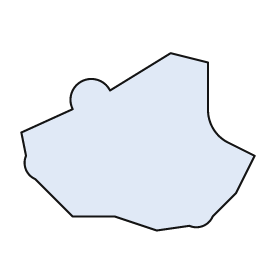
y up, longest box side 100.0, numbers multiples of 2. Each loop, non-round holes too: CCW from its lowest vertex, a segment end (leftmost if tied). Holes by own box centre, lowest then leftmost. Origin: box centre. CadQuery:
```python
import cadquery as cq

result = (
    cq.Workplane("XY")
    .moveTo(8.0, -38.0)
    .lineTo(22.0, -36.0)
    .threePointArc((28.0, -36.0), (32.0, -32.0))
    .lineTo(42.0, -22.0)
    .lineTo(50.0, -6.0)
    .lineTo(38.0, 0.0)
    .threePointArc((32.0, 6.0), (30.0, 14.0))
    .lineTo(30.0, 34.0)
    .lineTo(14.0, 38.0)
    .lineTo(-12.0, 22.0)
    .threePointArc((-24.0, 26.0), (-28.0, 14.0))
    .lineTo(-50.0, 4.0)
    .lineTo(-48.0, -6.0)
    .threePointArc((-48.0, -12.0), (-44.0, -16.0))
    .lineTo(-28.0, -32.0)
    .lineTo(-10.0, -32.0)
    .close()
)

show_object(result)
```